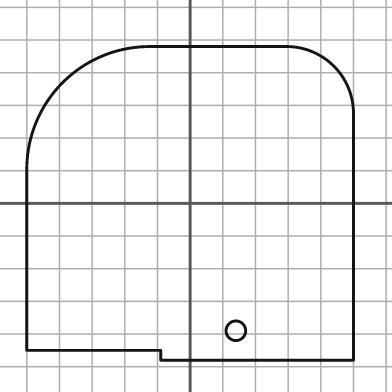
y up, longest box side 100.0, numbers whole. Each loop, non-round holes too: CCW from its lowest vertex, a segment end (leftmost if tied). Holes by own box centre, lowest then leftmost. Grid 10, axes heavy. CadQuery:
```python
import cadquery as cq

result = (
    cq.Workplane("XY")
    .moveTo(-9.0, -48.0)
    .lineTo(50.0, -48.0)
    .lineTo(50.0, 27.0)
    .threePointArc((44.0, 42.0), (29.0, 48.0))
    .lineTo(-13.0, 48.0)
    .threePointArc((-39.0, 37.0), (-50.0, 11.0))
    .lineTo(-50.0, -45.0)
    .lineTo(-9.0, -45.0)
    .close()
    .moveTo(14.0, -39.0)
    .circle(3.0)
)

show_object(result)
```